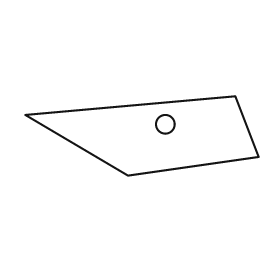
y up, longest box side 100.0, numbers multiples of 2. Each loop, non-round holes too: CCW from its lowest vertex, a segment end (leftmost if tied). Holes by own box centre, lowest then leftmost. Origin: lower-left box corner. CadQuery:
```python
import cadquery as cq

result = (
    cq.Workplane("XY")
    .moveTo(44.0, 0.0)
    .lineTo(100.0, 8.0)
    .lineTo(90.0, 34.0)
    .lineTo(0.0, 26.0)
    .close()
    .moveTo(60.0, 22.0)
    .circle(4.0)
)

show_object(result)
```